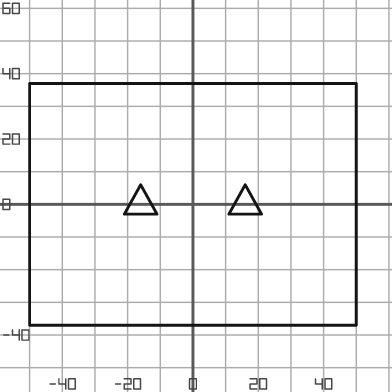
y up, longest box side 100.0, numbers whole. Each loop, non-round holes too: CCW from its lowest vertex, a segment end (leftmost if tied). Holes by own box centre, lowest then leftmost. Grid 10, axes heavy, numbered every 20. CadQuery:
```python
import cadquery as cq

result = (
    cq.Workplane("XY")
    .moveTo(-50.0, -37.0)
    .lineTo(50.0, -37.0)
    .lineTo(50.0, 37.0)
    .lineTo(-50.0, 37.0)
    .close()
    .moveTo(-21.0, -3.0)
    .lineTo(-11.0, -3.0)
    .lineTo(-16.0, 6.0)
    .close()
    .moveTo(11.0, -3.0)
    .lineTo(21.0, -3.0)
    .lineTo(16.0, 6.0)
    .close()
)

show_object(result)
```